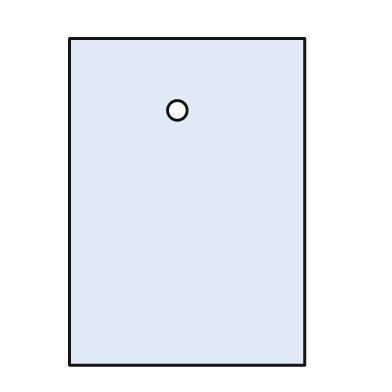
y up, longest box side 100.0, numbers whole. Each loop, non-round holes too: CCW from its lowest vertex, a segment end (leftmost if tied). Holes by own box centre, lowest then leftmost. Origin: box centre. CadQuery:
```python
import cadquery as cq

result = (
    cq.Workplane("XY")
    .moveTo(-36.0, -50.0)
    .lineTo(36.0, -50.0)
    .lineTo(36.0, 50.0)
    .lineTo(-36.0, 50.0)
    .close()
    .moveTo(-3.0, 28.0)
    .circle(3.0)
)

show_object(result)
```